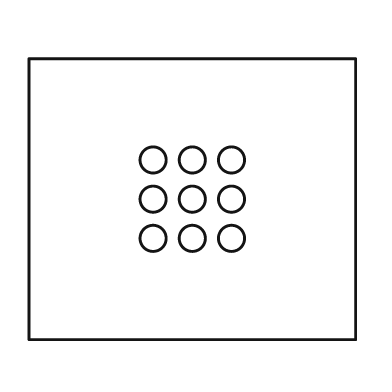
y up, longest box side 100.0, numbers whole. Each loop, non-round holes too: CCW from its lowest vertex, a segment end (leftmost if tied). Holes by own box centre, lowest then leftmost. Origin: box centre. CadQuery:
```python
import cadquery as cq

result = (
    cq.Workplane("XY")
    .moveTo(-50.0, -43.0)
    .lineTo(50.0, -43.0)
    .lineTo(50.0, 43.0)
    .lineTo(-50.0, 43.0)
    .close()
    .moveTo(-12.0, -12.0)
    .circle(4.0)
    .moveTo(0.0, -12.0)
    .circle(4.0)
    .moveTo(12.0, -12.0)
    .circle(4.0)
    .moveTo(-12.0, 0.0)
    .circle(4.0)
    .moveTo(0.0, 0.0)
    .circle(4.0)
    .moveTo(12.0, 0.0)
    .circle(4.0)
    .moveTo(-12.0, 12.0)
    .circle(4.0)
    .moveTo(0.0, 12.0)
    .circle(4.0)
    .moveTo(12.0, 12.0)
    .circle(4.0)
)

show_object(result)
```